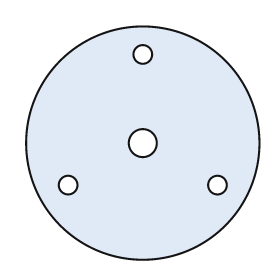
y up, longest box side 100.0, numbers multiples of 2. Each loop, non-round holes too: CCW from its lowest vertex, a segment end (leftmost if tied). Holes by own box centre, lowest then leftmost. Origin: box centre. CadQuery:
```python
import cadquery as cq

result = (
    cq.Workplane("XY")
    .moveTo(0.0, 0.0)
    .circle(50.0)
    .moveTo(-32.0, -18.0)
    .circle(4.0)
    .moveTo(32.0, -18.0)
    .circle(4.0)
    .moveTo(0.0, 0.0)
    .circle(6.0)
    .moveTo(0.0, 38.0)
    .circle(4.0)
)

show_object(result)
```